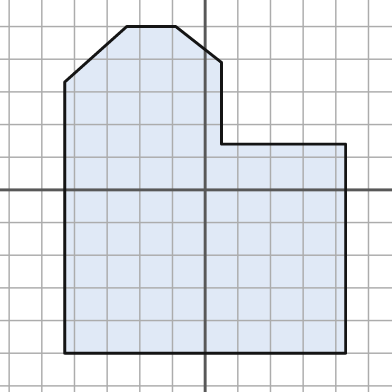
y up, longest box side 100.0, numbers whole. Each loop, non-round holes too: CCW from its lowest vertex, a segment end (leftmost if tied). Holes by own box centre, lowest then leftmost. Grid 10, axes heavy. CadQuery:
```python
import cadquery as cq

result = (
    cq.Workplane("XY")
    .moveTo(-43.0, -50.0)
    .lineTo(43.0, -50.0)
    .lineTo(43.0, 14.0)
    .lineTo(5.0, 14.0)
    .lineTo(5.0, 39.0)
    .lineTo(-9.0, 50.0)
    .lineTo(-24.0, 50.0)
    .lineTo(-43.0, 33.0)
    .close()
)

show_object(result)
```